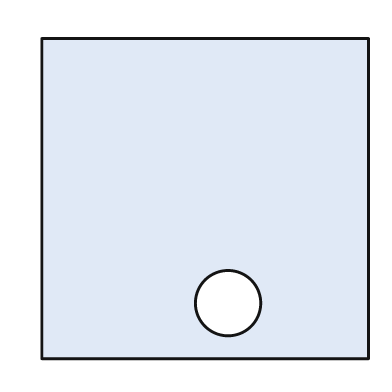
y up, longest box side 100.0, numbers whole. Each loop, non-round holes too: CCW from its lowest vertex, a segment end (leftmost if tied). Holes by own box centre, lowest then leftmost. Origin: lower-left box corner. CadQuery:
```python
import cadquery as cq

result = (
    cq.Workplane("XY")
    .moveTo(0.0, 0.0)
    .lineTo(100.0, 0.0)
    .lineTo(100.0, 98.0)
    .lineTo(0.0, 98.0)
    .close()
    .moveTo(57.0, 17.0)
    .circle(10.0)
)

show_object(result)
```